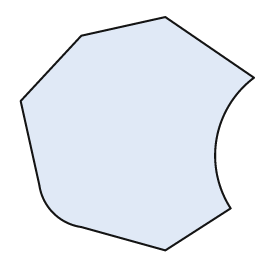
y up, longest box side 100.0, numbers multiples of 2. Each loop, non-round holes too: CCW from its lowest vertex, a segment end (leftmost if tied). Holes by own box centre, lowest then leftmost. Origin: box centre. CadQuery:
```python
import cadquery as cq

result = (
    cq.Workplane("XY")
    .moveTo(12.0, -50.0)
    .lineTo(40.0, -32.0)
    .threePointArc((34.0, -2.0), (50.0, 24.0))
    .lineTo(12.0, 50.0)
    .lineTo(-24.0, 42.0)
    .lineTo(-50.0, 14.0)
    .lineTo(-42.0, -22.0)
    .threePointArc((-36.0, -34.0), (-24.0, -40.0))
    .close()
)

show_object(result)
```